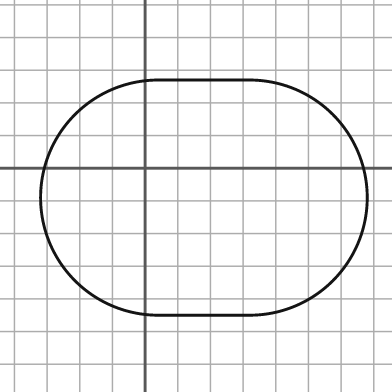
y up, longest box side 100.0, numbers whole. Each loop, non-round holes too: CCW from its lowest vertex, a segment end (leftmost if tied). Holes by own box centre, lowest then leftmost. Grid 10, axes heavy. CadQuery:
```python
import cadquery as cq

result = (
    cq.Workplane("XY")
    .moveTo(4.0, -45.0)
    .lineTo(32.0, -45.0)
    .threePointArc((68.0, -9.0), (32.0, 27.0))
    .lineTo(4.0, 27.0)
    .threePointArc((-32.0, -9.0), (4.0, -45.0))
    .close()
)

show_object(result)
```